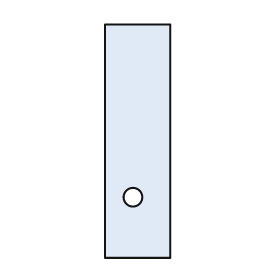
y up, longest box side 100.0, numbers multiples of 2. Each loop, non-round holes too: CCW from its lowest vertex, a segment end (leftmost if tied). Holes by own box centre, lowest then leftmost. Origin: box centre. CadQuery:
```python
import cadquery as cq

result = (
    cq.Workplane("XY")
    .moveTo(-14.0, -50.0)
    .lineTo(14.0, -50.0)
    .lineTo(14.0, 50.0)
    .lineTo(-14.0, 50.0)
    .close()
    .moveTo(-2.0, -24.0)
    .circle(4.0)
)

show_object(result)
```